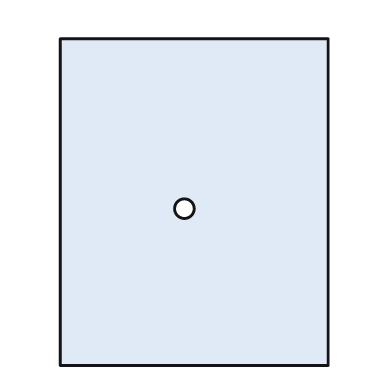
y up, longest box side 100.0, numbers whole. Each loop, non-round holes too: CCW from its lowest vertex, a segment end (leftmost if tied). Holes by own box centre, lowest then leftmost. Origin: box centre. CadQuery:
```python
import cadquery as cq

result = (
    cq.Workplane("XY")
    .moveTo(-41.0, -50.0)
    .lineTo(41.0, -50.0)
    .lineTo(41.0, 50.0)
    .lineTo(-41.0, 50.0)
    .close()
    .moveTo(-3.0, -2.0)
    .circle(3.0)
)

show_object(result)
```